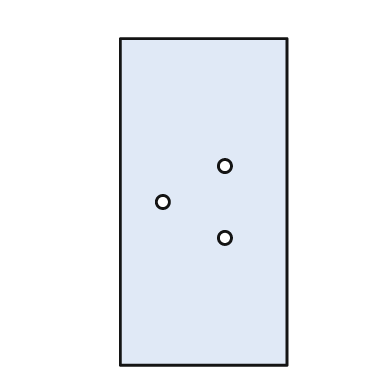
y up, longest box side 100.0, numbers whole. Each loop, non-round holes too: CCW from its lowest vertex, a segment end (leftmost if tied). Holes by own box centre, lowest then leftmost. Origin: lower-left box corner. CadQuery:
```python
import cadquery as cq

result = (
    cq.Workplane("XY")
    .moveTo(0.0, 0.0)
    .lineTo(51.0, 0.0)
    .lineTo(51.0, 100.0)
    .lineTo(0.0, 100.0)
    .close()
    .moveTo(32.0, 39.0)
    .circle(2.0)
    .moveTo(13.0, 50.0)
    .circle(2.0)
    .moveTo(32.0, 61.0)
    .circle(2.0)
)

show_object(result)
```